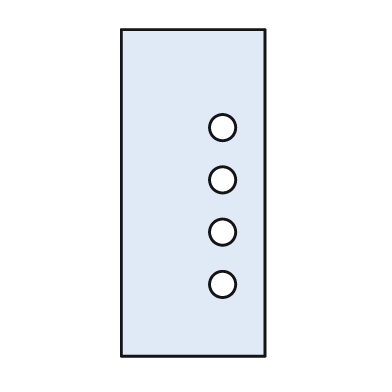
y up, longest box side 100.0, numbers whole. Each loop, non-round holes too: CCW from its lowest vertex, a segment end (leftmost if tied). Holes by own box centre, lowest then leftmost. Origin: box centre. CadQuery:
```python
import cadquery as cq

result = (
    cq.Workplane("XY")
    .moveTo(-22.0, -50.0)
    .lineTo(22.0, -50.0)
    .lineTo(22.0, 50.0)
    .lineTo(-22.0, 50.0)
    .close()
    .moveTo(9.0, -28.0)
    .circle(4.0)
    .moveTo(9.0, -12.0)
    .circle(4.0)
    .moveTo(9.0, 4.0)
    .circle(4.0)
    .moveTo(9.0, 20.0)
    .circle(4.0)
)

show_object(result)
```